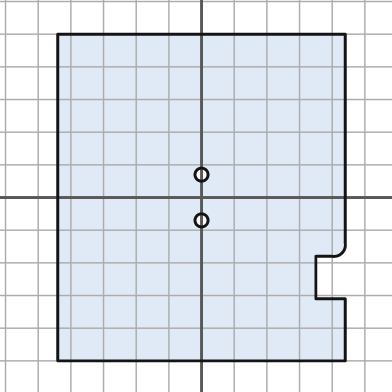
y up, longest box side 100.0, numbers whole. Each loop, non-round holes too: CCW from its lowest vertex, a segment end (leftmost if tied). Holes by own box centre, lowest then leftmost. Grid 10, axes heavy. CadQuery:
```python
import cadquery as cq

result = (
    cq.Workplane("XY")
    .moveTo(-44.0, -50.0)
    .lineTo(44.0, -50.0)
    .lineTo(44.0, -31.0)
    .lineTo(35.0, -31.0)
    .lineTo(35.0, -18.0)
    .lineTo(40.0, -18.0)
    .threePointArc((43.0, -17.0), (44.0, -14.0))
    .lineTo(44.0, 50.0)
    .lineTo(-44.0, 50.0)
    .close()
    .moveTo(0.0, -7.0)
    .circle(2.0)
    .moveTo(0.0, 7.0)
    .circle(2.0)
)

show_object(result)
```